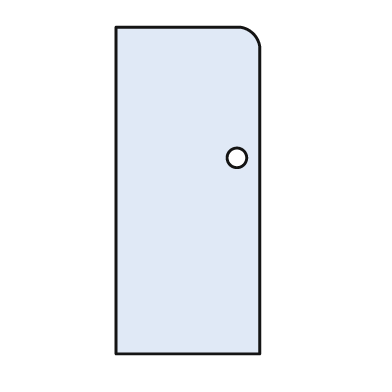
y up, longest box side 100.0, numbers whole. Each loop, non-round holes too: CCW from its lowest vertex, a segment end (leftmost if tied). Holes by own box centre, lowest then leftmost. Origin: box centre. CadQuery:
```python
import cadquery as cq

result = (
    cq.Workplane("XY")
    .moveTo(-22.0, -50.0)
    .lineTo(22.0, -50.0)
    .lineTo(22.0, 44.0)
    .threePointArc((20.0, 48.0), (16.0, 50.0))
    .lineTo(-22.0, 50.0)
    .close()
    .moveTo(15.0, 10.0)
    .circle(3.0)
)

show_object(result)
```